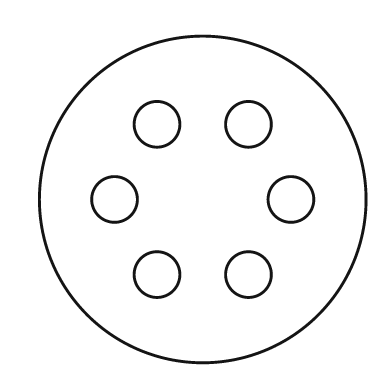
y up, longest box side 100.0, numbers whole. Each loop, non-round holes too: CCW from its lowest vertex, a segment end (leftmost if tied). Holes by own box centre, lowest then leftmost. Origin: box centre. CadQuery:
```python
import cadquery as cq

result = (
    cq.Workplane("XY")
    .moveTo(0.0, 0.0)
    .circle(50.0)
    .moveTo(-14.0, -23.0)
    .circle(7.0)
    .moveTo(14.0, -23.0)
    .circle(7.0)
    .moveTo(-27.0, 0.0)
    .circle(7.0)
    .moveTo(27.0, 0.0)
    .circle(7.0)
    .moveTo(-14.0, 23.0)
    .circle(7.0)
    .moveTo(14.0, 23.0)
    .circle(7.0)
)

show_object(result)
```